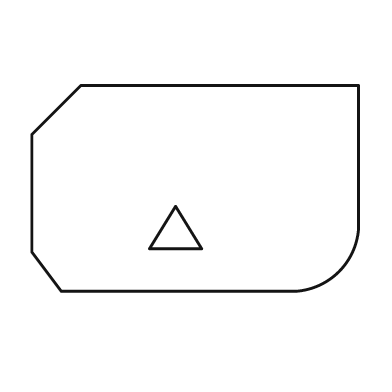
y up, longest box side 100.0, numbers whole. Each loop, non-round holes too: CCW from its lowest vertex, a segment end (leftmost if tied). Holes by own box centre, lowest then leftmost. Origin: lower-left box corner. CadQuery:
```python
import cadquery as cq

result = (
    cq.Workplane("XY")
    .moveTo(9.0, 0.0)
    .lineTo(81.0, 0.0)
    .threePointArc((94.0, 6.0), (100.0, 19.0))
    .lineTo(100.0, 63.0)
    .lineTo(15.0, 63.0)
    .lineTo(0.0, 48.0)
    .lineTo(0.0, 12.0)
    .close()
    .moveTo(36.0, 13.0)
    .lineTo(52.0, 13.0)
    .lineTo(44.0, 26.0)
    .close()
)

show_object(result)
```